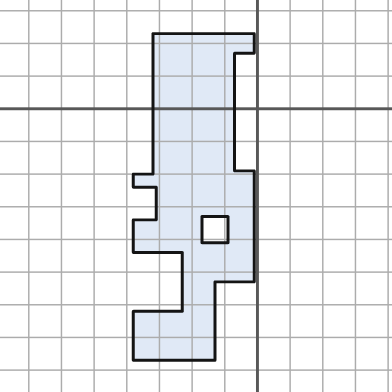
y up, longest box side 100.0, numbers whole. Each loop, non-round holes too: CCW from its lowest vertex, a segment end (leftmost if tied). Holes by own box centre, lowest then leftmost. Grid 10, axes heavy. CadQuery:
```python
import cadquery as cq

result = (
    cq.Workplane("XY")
    .moveTo(-38.0, -77.0)
    .lineTo(-13.0, -77.0)
    .lineTo(-13.0, -53.0)
    .lineTo(-1.0, -53.0)
    .lineTo(-1.0, -19.0)
    .lineTo(-7.0, -19.0)
    .lineTo(-7.0, 17.0)
    .lineTo(-1.0, 17.0)
    .lineTo(-1.0, 23.0)
    .lineTo(-32.0, 23.0)
    .lineTo(-32.0, -20.0)
    .lineTo(-38.0, -20.0)
    .lineTo(-38.0, -24.0)
    .lineTo(-31.0, -24.0)
    .lineTo(-31.0, -34.0)
    .lineTo(-38.0, -34.0)
    .lineTo(-38.0, -44.0)
    .lineTo(-23.0, -44.0)
    .lineTo(-23.0, -62.0)
    .lineTo(-38.0, -62.0)
    .close()
    .moveTo(-17.0, -41.0)
    .lineTo(-9.0, -41.0)
    .lineTo(-9.0, -33.0)
    .lineTo(-17.0, -33.0)
    .close()
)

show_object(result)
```